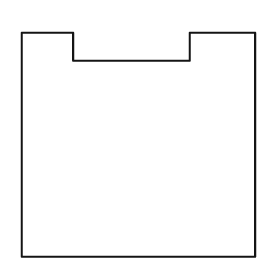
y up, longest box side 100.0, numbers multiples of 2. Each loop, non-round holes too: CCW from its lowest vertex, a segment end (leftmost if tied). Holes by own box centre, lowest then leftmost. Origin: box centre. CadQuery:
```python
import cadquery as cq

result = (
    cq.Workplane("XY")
    .moveTo(-50.0, -48.0)
    .lineTo(50.0, -48.0)
    .lineTo(50.0, 48.0)
    .lineTo(22.0, 48.0)
    .lineTo(22.0, 36.0)
    .lineTo(-28.0, 36.0)
    .lineTo(-28.0, 48.0)
    .lineTo(-50.0, 48.0)
    .close()
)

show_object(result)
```